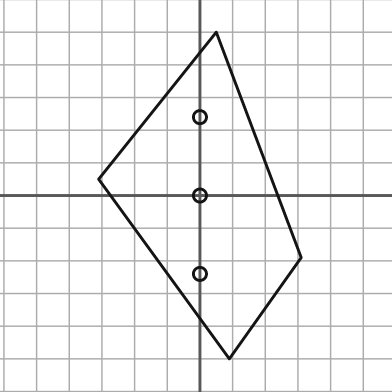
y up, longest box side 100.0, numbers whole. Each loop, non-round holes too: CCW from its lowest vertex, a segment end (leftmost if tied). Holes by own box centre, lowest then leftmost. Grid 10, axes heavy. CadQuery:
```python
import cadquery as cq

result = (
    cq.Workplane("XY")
    .moveTo(9.0, -50.0)
    .lineTo(31.0, -19.0)
    .lineTo(5.0, 50.0)
    .lineTo(-31.0, 5.0)
    .close()
    .moveTo(0.0, -24.0)
    .circle(2.0)
    .moveTo(0.0, 0.0)
    .circle(2.0)
    .moveTo(0.0, 24.0)
    .circle(2.0)
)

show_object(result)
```